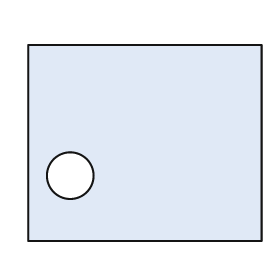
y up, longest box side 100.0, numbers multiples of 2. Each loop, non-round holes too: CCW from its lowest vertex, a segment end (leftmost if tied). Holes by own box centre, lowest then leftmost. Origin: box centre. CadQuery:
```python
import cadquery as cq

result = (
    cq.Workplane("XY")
    .moveTo(-50.0, -42.0)
    .lineTo(50.0, -42.0)
    .lineTo(50.0, 42.0)
    .lineTo(-50.0, 42.0)
    .close()
    .moveTo(-32.0, -14.0)
    .circle(10.0)
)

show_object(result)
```